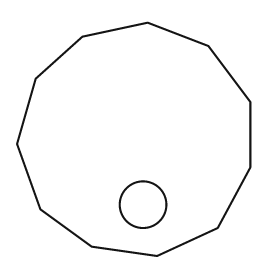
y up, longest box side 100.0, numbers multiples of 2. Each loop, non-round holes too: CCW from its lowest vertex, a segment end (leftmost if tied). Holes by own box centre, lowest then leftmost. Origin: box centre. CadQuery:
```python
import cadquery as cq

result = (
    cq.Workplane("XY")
    .moveTo(10.0, -50.0)
    .lineTo(36.0, -38.0)
    .lineTo(50.0, -12.0)
    .lineTo(50.0, 16.0)
    .lineTo(32.0, 40.0)
    .lineTo(6.0, 50.0)
    .lineTo(-22.0, 44.0)
    .lineTo(-42.0, 26.0)
    .lineTo(-50.0, -2.0)
    .lineTo(-40.0, -30.0)
    .lineTo(-18.0, -46.0)
    .close()
    .moveTo(4.0, -28.0)
    .circle(10.0)
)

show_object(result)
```